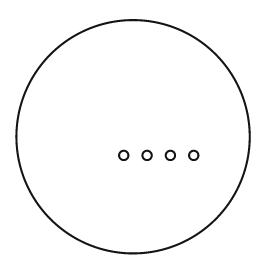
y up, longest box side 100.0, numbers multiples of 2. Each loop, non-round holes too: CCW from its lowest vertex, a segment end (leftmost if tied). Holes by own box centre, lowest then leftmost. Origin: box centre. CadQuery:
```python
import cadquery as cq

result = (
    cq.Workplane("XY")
    .moveTo(0.0, 0.0)
    .circle(50.0)
    .moveTo(-4.0, -8.0)
    .circle(2.0)
    .moveTo(6.0, -8.0)
    .circle(2.0)
    .moveTo(16.0, -8.0)
    .circle(2.0)
    .moveTo(26.0, -8.0)
    .circle(2.0)
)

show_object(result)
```